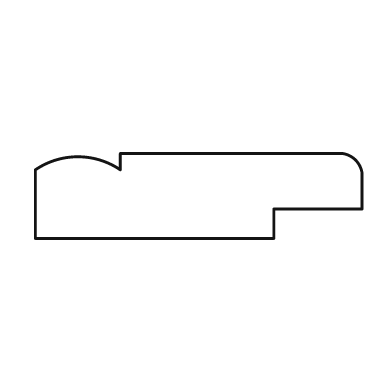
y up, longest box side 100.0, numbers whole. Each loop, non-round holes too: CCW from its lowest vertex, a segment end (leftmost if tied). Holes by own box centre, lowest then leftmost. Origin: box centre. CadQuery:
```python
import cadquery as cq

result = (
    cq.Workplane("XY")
    .moveTo(-50.0, -13.0)
    .lineTo(23.0, -13.0)
    .lineTo(23.0, -4.0)
    .lineTo(50.0, -4.0)
    .lineTo(50.0, 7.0)
    .threePointArc((48.0, 11.0), (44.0, 13.0))
    .lineTo(-24.0, 13.0)
    .lineTo(-24.0, 8.0)
    .threePointArc((-37.0, 12.0), (-50.0, 8.0))
    .close()
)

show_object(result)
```